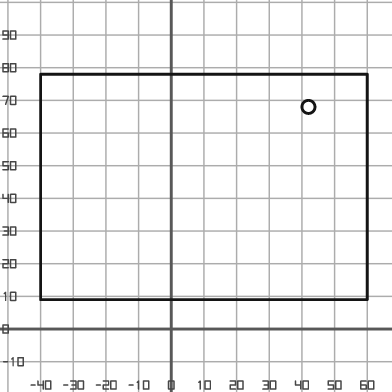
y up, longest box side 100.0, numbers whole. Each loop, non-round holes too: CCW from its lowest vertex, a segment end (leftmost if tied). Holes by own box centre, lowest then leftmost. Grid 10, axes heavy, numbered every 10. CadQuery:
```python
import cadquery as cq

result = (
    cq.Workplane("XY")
    .moveTo(-40.0, 9.0)
    .lineTo(60.0, 9.0)
    .lineTo(60.0, 78.0)
    .lineTo(-40.0, 78.0)
    .close()
    .moveTo(42.0, 68.0)
    .circle(2.0)
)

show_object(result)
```